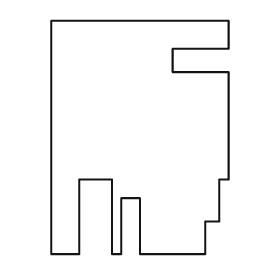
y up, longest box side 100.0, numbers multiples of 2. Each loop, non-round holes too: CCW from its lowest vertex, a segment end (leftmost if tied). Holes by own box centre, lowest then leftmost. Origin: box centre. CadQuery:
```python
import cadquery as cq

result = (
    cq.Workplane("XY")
    .moveTo(-38.0, -50.0)
    .lineTo(-26.0, -50.0)
    .lineTo(-26.0, -18.0)
    .lineTo(-12.0, -18.0)
    .lineTo(-12.0, -50.0)
    .lineTo(-8.0, -50.0)
    .lineTo(-8.0, -26.0)
    .lineTo(0.0, -26.0)
    .lineTo(0.0, -50.0)
    .lineTo(28.0, -50.0)
    .lineTo(28.0, -36.0)
    .lineTo(34.0, -36.0)
    .lineTo(34.0, -18.0)
    .lineTo(38.0, -18.0)
    .lineTo(38.0, 28.0)
    .lineTo(14.0, 28.0)
    .lineTo(14.0, 38.0)
    .lineTo(38.0, 38.0)
    .lineTo(38.0, 50.0)
    .lineTo(-38.0, 50.0)
    .close()
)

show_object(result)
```